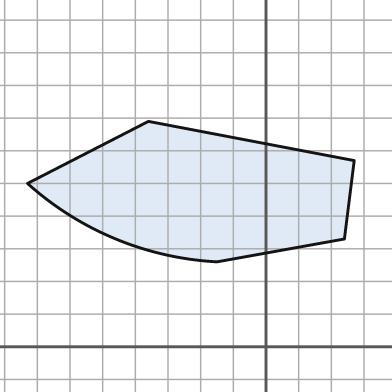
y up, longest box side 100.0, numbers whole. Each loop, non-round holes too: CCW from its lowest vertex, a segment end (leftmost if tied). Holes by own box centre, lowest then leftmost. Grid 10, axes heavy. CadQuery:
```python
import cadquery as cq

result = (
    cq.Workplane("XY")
    .moveTo(-15.0, 26.0)
    .lineTo(24.0, 33.0)
    .lineTo(27.0, 57.0)
    .lineTo(-36.0, 69.0)
    .lineTo(-73.0, 50.0)
    .threePointArc((-46.0, 33.0), (-15.0, 26.0))
    .close()
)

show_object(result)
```